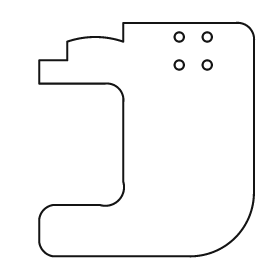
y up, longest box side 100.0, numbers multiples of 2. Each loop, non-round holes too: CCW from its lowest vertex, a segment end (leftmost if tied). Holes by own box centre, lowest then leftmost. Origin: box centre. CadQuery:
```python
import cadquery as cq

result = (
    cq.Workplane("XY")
    .moveTo(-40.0, -50.0)
    .lineTo(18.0, -50.0)
    .threePointArc((38.0, -42.0), (46.0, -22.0))
    .lineTo(46.0, 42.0)
    .threePointArc((44.0, 48.0), (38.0, 50.0))
    .lineTo(-10.0, 50.0)
    .lineTo(-10.0, 42.0)
    .threePointArc((-22.0, 44.0), (-34.0, 42.0))
    .lineTo(-34.0, 34.0)
    .lineTo(-46.0, 34.0)
    .lineTo(-46.0, 24.0)
    .lineTo(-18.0, 24.0)
    .threePointArc((-12.0, 22.0), (-10.0, 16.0))
    .lineTo(-10.0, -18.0)
    .threePointArc((-12.0, -26.0), (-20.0, -28.0))
    .lineTo(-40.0, -28.0)
    .threePointArc((-44.0, -30.0), (-46.0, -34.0))
    .lineTo(-46.0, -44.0)
    .threePointArc((-44.0, -48.0), (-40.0, -50.0))
    .close()
    .moveTo(14.0, 32.0)
    .circle(2.0)
    .moveTo(26.0, 32.0)
    .circle(2.0)
    .moveTo(14.0, 44.0)
    .circle(2.0)
    .moveTo(26.0, 44.0)
    .circle(2.0)
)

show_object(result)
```